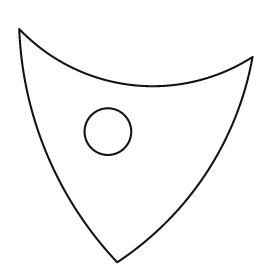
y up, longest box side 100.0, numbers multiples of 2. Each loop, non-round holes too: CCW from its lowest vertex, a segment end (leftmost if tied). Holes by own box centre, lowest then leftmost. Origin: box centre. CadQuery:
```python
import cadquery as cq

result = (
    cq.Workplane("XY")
    .moveTo(-8.0, -50.0)
    .threePointArc((30.0, -12.0), (50.0, 38.0))
    .threePointArc((-2.0, 26.0), (-50.0, 50.0))
    .threePointArc((-38.0, -4.0), (-8.0, -50.0))
    .close()
    .moveTo(-12.0, 6.0)
    .circle(10.0)
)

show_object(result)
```